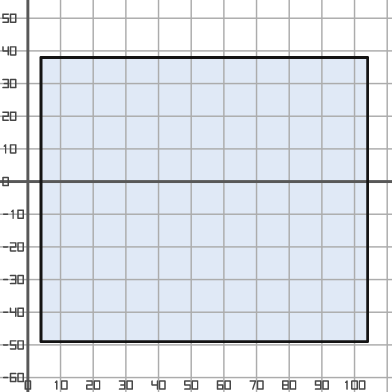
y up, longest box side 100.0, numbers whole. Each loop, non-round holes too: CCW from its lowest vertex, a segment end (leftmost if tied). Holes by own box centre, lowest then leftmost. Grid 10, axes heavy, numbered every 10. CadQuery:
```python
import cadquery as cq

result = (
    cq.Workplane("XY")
    .moveTo(4.0, -49.0)
    .lineTo(104.0, -49.0)
    .lineTo(104.0, 38.0)
    .lineTo(4.0, 38.0)
    .close()
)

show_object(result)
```